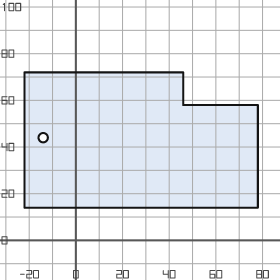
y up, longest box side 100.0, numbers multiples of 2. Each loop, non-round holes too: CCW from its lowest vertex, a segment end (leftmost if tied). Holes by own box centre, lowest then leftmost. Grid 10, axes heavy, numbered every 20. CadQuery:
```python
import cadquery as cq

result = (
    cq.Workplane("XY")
    .moveTo(-22.0, 14.0)
    .lineTo(78.0, 14.0)
    .lineTo(78.0, 58.0)
    .lineTo(46.0, 58.0)
    .lineTo(46.0, 72.0)
    .lineTo(-22.0, 72.0)
    .close()
    .moveTo(-14.0, 44.0)
    .circle(2.0)
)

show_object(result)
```